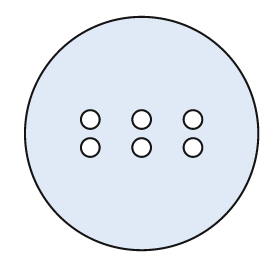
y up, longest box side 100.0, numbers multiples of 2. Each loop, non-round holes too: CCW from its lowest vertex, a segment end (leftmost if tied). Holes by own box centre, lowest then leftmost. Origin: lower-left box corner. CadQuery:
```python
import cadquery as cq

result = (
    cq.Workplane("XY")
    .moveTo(50.0, 50.0)
    .circle(50.0)
    .moveTo(28.0, 44.0)
    .circle(4.0)
    .moveTo(50.0, 44.0)
    .circle(4.0)
    .moveTo(72.0, 44.0)
    .circle(4.0)
    .moveTo(28.0, 56.0)
    .circle(4.0)
    .moveTo(50.0, 56.0)
    .circle(4.0)
    .moveTo(72.0, 56.0)
    .circle(4.0)
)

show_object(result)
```